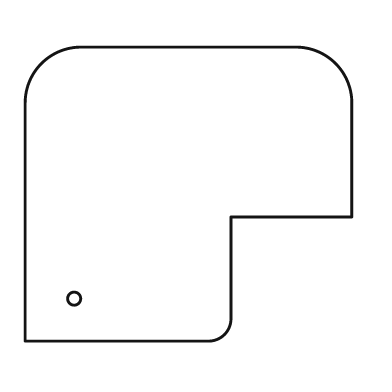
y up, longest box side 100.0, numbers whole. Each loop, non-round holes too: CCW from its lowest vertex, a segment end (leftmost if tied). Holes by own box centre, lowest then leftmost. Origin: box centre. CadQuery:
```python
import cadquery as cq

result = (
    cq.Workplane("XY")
    .moveTo(-50.0, -45.0)
    .lineTo(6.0, -45.0)
    .threePointArc((11.0, -43.0), (13.0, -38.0))
    .lineTo(13.0, -7.0)
    .lineTo(50.0, -7.0)
    .lineTo(50.0, 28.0)
    .threePointArc((45.0, 40.0), (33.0, 45.0))
    .lineTo(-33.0, 45.0)
    .threePointArc((-45.0, 40.0), (-50.0, 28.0))
    .close()
    .moveTo(-35.0, -32.0)
    .circle(2.0)
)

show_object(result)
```